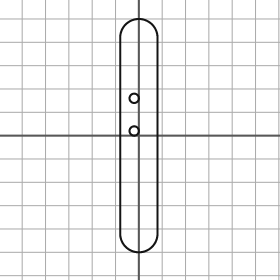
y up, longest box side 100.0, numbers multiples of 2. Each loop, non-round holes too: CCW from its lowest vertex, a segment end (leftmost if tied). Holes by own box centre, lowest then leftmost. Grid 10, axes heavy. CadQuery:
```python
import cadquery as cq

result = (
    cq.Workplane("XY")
    .moveTo(-8.0, -42.0)
    .threePointArc((0.0, -50.0), (8.0, -42.0))
    .lineTo(8.0, 42.0)
    .threePointArc((0.0, 50.0), (-8.0, 42.0))
    .close()
    .moveTo(-2.0, 2.0)
    .circle(2.0)
    .moveTo(-2.0, 16.0)
    .circle(2.0)
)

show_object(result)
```